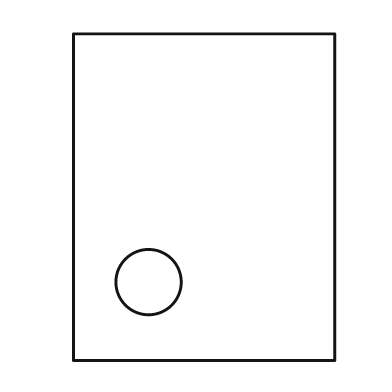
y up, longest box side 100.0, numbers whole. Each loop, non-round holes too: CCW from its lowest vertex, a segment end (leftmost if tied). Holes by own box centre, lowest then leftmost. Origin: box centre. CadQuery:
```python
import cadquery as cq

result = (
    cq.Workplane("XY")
    .moveTo(-40.0, -50.0)
    .lineTo(40.0, -50.0)
    .lineTo(40.0, 50.0)
    .lineTo(-40.0, 50.0)
    .close()
    .moveTo(-17.0, -26.0)
    .circle(10.0)
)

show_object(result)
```